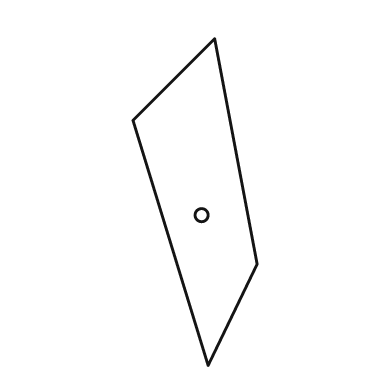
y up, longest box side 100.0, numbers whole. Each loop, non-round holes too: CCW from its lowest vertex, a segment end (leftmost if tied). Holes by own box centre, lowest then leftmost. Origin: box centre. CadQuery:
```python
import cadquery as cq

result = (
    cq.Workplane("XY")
    .moveTo(4.0, -50.0)
    .lineTo(19.0, -19.0)
    .lineTo(6.0, 50.0)
    .lineTo(-19.0, 25.0)
    .close()
    .moveTo(2.0, -4.0)
    .circle(2.0)
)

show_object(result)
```